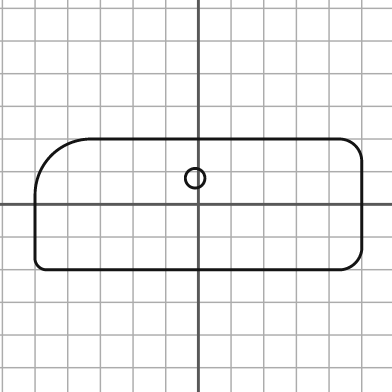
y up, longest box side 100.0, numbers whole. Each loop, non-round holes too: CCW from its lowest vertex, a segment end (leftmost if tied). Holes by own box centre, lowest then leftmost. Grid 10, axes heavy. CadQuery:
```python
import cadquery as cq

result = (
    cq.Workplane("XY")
    .moveTo(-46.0, -20.0)
    .lineTo(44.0, -20.0)
    .threePointArc((48.0, -18.0), (50.0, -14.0))
    .lineTo(50.0, 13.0)
    .threePointArc((48.0, 18.0), (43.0, 20.0))
    .lineTo(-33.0, 20.0)
    .threePointArc((-45.0, 15.0), (-50.0, 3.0))
    .lineTo(-50.0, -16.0)
    .threePointArc((-49.0, -19.0), (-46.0, -20.0))
    .close()
    .moveTo(-1.0, 8.0)
    .circle(3.0)
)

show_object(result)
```